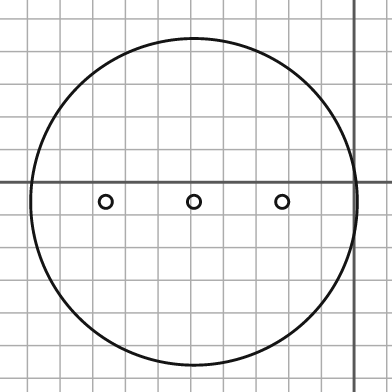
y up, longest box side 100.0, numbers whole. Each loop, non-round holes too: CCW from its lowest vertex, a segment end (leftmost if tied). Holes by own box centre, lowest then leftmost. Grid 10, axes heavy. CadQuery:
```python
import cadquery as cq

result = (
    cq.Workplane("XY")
    .moveTo(-49.0, -6.0)
    .circle(50.0)
    .moveTo(-76.0, -6.0)
    .circle(2.0)
    .moveTo(-49.0, -6.0)
    .circle(2.0)
    .moveTo(-22.0, -6.0)
    .circle(2.0)
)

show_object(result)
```